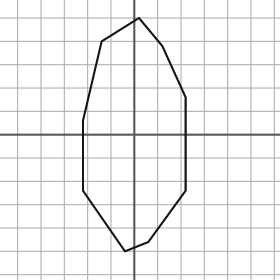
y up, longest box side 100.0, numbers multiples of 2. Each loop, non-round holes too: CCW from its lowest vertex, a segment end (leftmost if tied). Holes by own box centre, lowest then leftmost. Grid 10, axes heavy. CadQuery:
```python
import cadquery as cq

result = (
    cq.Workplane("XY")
    .moveTo(-4.0, -50.0)
    .lineTo(6.0, -46.0)
    .lineTo(22.0, -24.0)
    .lineTo(22.0, 16.0)
    .lineTo(12.0, 38.0)
    .lineTo(2.0, 50.0)
    .lineTo(-14.0, 40.0)
    .lineTo(-22.0, 6.0)
    .lineTo(-22.0, -24.0)
    .close()
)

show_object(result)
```